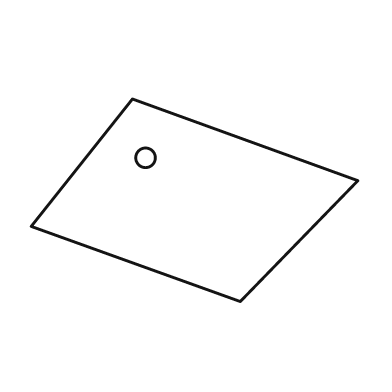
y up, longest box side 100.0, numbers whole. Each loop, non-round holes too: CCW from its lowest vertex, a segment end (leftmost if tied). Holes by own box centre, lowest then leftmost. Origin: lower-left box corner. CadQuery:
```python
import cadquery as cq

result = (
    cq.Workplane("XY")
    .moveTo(64.0, 0.0)
    .lineTo(100.0, 37.0)
    .lineTo(31.0, 62.0)
    .lineTo(0.0, 23.0)
    .close()
    .moveTo(35.0, 44.0)
    .circle(3.0)
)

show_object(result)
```